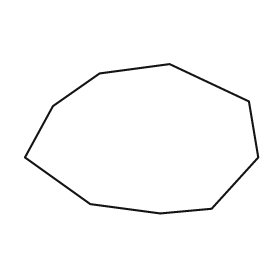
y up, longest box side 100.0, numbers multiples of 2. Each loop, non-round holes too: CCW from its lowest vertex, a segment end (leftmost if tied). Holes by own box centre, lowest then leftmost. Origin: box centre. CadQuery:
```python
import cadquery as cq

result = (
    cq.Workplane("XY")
    .moveTo(8.0, -32.0)
    .lineTo(30.0, -30.0)
    .lineTo(50.0, -8.0)
    .lineTo(46.0, 16.0)
    .lineTo(12.0, 32.0)
    .lineTo(-18.0, 28.0)
    .lineTo(-38.0, 14.0)
    .lineTo(-50.0, -8.0)
    .lineTo(-22.0, -28.0)
    .close()
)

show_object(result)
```